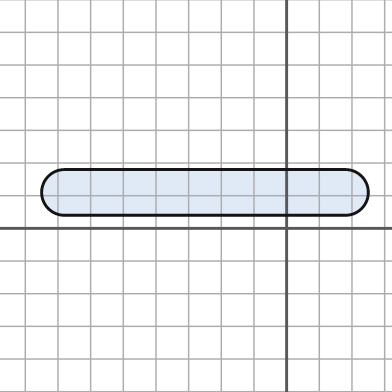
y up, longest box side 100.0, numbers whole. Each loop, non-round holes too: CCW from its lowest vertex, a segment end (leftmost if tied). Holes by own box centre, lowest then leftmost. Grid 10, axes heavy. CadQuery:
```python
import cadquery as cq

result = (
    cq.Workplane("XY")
    .moveTo(-68.0, 4.0)
    .lineTo(18.0, 4.0)
    .threePointArc((25.0, 11.0), (18.0, 18.0))
    .lineTo(-68.0, 18.0)
    .threePointArc((-75.0, 11.0), (-68.0, 4.0))
    .close()
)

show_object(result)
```